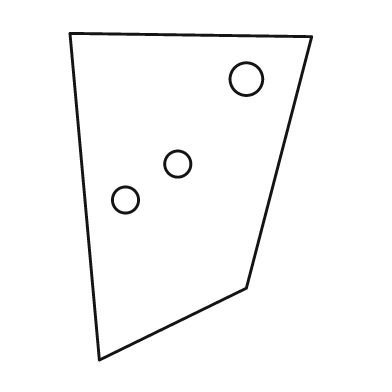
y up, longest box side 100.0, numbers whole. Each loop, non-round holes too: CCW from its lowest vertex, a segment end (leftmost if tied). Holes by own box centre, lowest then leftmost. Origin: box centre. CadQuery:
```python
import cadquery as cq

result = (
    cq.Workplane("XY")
    .moveTo(-28.0, -50.0)
    .lineTo(17.0, -28.0)
    .lineTo(37.0, 49.0)
    .lineTo(-37.0, 50.0)
    .close()
    .moveTo(-20.0, -1.0)
    .circle(4.0)
    .moveTo(-4.0, 10.0)
    .circle(4.0)
    .moveTo(17.0, 36.0)
    .circle(5.0)
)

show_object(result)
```